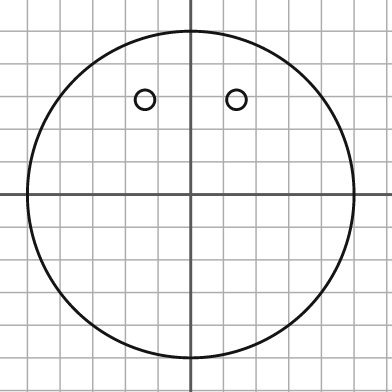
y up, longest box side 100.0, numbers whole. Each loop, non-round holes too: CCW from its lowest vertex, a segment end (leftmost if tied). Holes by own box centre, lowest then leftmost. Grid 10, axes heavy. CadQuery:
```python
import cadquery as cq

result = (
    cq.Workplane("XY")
    .moveTo(0.0, 0.0)
    .circle(50.0)
    .moveTo(-14.0, 29.0)
    .circle(3.0)
    .moveTo(14.0, 29.0)
    .circle(3.0)
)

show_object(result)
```